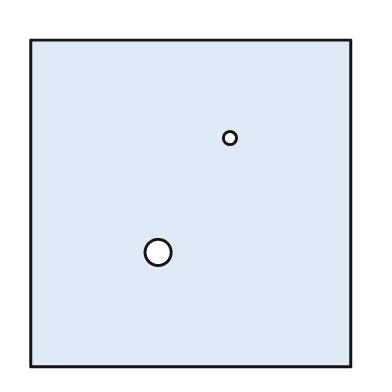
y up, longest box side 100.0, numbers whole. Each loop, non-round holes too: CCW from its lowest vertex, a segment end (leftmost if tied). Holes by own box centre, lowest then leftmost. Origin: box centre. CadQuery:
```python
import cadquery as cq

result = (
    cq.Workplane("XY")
    .moveTo(-49.0, -50.0)
    .lineTo(49.0, -50.0)
    .lineTo(49.0, 50.0)
    .lineTo(-49.0, 50.0)
    .close()
    .moveTo(-10.0, -15.0)
    .circle(4.0)
    .moveTo(12.0, 20.0)
    .circle(2.0)
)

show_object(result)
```